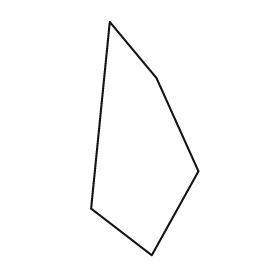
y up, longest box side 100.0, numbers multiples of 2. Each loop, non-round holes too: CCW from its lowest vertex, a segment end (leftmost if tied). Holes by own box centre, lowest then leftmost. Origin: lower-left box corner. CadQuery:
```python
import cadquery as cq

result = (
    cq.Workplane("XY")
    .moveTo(26.0, 0.0)
    .lineTo(46.0, 36.0)
    .lineTo(28.0, 76.0)
    .lineTo(8.0, 100.0)
    .lineTo(0.0, 20.0)
    .close()
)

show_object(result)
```